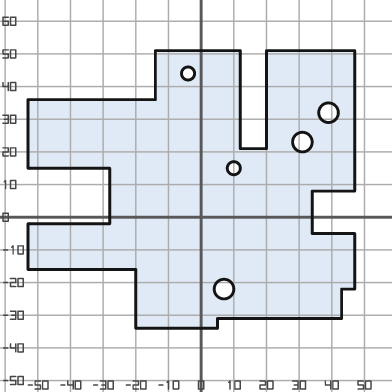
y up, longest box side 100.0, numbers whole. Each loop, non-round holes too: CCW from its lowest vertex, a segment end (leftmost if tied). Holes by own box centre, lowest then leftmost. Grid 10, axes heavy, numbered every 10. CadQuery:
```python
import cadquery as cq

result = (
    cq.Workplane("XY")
    .moveTo(-20.0, -34.0)
    .lineTo(5.0, -34.0)
    .lineTo(5.0, -31.0)
    .lineTo(43.0, -31.0)
    .lineTo(43.0, -22.0)
    .lineTo(47.0, -22.0)
    .lineTo(47.0, -5.0)
    .lineTo(34.0, -5.0)
    .lineTo(34.0, 8.0)
    .lineTo(47.0, 8.0)
    .lineTo(47.0, 51.0)
    .lineTo(20.0, 51.0)
    .lineTo(20.0, 21.0)
    .lineTo(12.0, 21.0)
    .lineTo(12.0, 51.0)
    .lineTo(-14.0, 51.0)
    .lineTo(-14.0, 36.0)
    .lineTo(-53.0, 36.0)
    .lineTo(-53.0, 15.0)
    .lineTo(-28.0, 15.0)
    .lineTo(-28.0, -2.0)
    .lineTo(-53.0, -2.0)
    .lineTo(-53.0, -16.0)
    .lineTo(-20.0, -16.0)
    .close()
    .moveTo(7.0, -22.0)
    .circle(3.0)
    .moveTo(10.0, 15.0)
    .circle(2.0)
    .moveTo(31.0, 23.0)
    .circle(3.0)
    .moveTo(39.0, 32.0)
    .circle(3.0)
    .moveTo(-4.0, 44.0)
    .circle(2.0)
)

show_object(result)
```